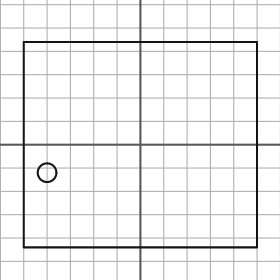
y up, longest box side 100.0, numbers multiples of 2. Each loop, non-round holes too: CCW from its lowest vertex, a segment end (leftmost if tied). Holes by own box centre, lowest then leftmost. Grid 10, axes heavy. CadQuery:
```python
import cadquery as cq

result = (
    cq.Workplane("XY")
    .moveTo(-50.0, -44.0)
    .lineTo(50.0, -44.0)
    .lineTo(50.0, 44.0)
    .lineTo(-50.0, 44.0)
    .close()
    .moveTo(-40.0, -12.0)
    .circle(4.0)
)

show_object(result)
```